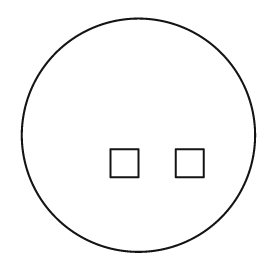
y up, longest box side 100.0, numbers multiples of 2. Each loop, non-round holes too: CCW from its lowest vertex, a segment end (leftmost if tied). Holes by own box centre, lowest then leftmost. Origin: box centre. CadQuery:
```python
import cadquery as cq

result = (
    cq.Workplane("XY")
    .moveTo(0.0, 0.0)
    .circle(50.0)
    .moveTo(-12.0, -18.0)
    .lineTo(0.0, -18.0)
    .lineTo(0.0, -6.0)
    .lineTo(-12.0, -6.0)
    .close()
    .moveTo(16.0, -18.0)
    .lineTo(28.0, -18.0)
    .lineTo(28.0, -6.0)
    .lineTo(16.0, -6.0)
    .close()
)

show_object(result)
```